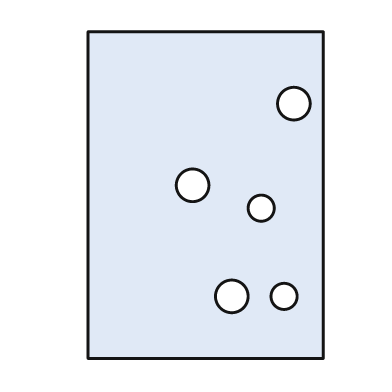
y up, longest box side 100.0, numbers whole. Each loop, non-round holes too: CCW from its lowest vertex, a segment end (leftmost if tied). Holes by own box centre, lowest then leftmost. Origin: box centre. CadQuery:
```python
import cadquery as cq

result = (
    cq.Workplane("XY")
    .moveTo(-36.0, -50.0)
    .lineTo(36.0, -50.0)
    .lineTo(36.0, 50.0)
    .lineTo(-36.0, 50.0)
    .close()
    .moveTo(8.0, -31.0)
    .circle(5.0)
    .moveTo(24.0, -31.0)
    .circle(4.0)
    .moveTo(17.0, -4.0)
    .circle(4.0)
    .moveTo(-4.0, 3.0)
    .circle(5.0)
    .moveTo(27.0, 28.0)
    .circle(5.0)
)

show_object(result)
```